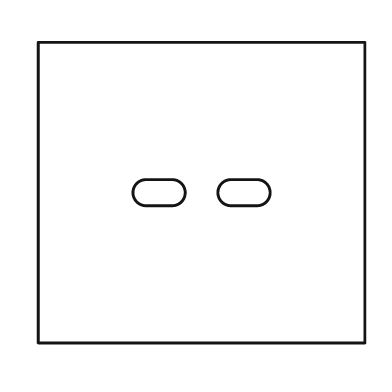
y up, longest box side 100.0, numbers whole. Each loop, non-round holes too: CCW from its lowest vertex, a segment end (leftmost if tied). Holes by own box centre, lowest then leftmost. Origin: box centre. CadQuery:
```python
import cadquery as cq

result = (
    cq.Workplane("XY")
    .moveTo(-50.0, -46.0)
    .lineTo(50.0, -46.0)
    .lineTo(50.0, 46.0)
    .lineTo(-50.0, 46.0)
    .close()
    .moveTo(-17.0, -4.0)
    .lineTo(-9.0, -4.0)
    .threePointArc((-5.0, 0.0), (-9.0, 4.0))
    .lineTo(-17.0, 4.0)
    .threePointArc((-21.0, 0.0), (-17.0, -4.0))
    .close()
    .moveTo(9.0, -4.0)
    .lineTo(17.0, -4.0)
    .threePointArc((21.0, 0.0), (17.0, 4.0))
    .lineTo(9.0, 4.0)
    .threePointArc((5.0, 0.0), (9.0, -4.0))
    .close()
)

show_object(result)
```